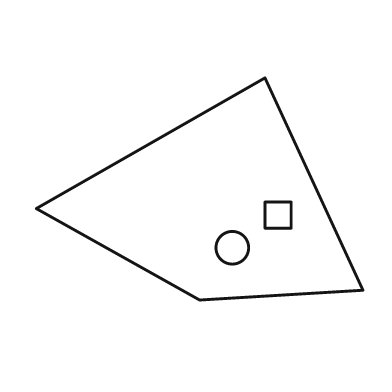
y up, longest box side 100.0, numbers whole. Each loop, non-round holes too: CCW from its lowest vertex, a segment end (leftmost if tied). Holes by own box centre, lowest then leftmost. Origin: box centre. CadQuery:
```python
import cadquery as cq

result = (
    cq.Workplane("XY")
    .moveTo(0.0, -34.0)
    .lineTo(50.0, -31.0)
    .lineTo(20.0, 34.0)
    .lineTo(-50.0, -6.0)
    .close()
    .moveTo(10.0, -18.0)
    .circle(5.0)
    .moveTo(20.0, -12.0)
    .lineTo(28.0, -12.0)
    .lineTo(28.0, -4.0)
    .lineTo(20.0, -4.0)
    .close()
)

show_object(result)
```